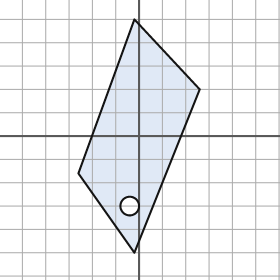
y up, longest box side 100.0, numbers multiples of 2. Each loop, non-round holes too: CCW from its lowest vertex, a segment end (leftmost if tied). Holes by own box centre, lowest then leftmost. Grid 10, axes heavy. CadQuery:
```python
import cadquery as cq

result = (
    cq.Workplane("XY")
    .moveTo(-2.0, -50.0)
    .lineTo(26.0, 20.0)
    .lineTo(-2.0, 50.0)
    .lineTo(-26.0, -16.0)
    .close()
    .moveTo(-4.0, -30.0)
    .circle(4.0)
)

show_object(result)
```